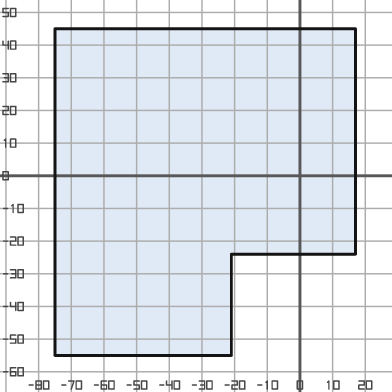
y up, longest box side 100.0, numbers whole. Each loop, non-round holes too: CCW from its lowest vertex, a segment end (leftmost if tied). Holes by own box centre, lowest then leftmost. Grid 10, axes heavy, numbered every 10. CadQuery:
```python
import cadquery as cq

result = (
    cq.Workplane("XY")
    .moveTo(-75.0, -55.0)
    .lineTo(-21.0, -55.0)
    .lineTo(-21.0, -24.0)
    .lineTo(17.0, -24.0)
    .lineTo(17.0, 45.0)
    .lineTo(-75.0, 45.0)
    .close()
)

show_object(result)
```